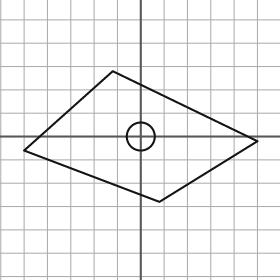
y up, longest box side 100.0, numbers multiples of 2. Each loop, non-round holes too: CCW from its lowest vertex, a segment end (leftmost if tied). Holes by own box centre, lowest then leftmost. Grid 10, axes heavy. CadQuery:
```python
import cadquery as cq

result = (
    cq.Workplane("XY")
    .moveTo(8.0, -28.0)
    .lineTo(50.0, -2.0)
    .lineTo(-12.0, 28.0)
    .lineTo(-50.0, -6.0)
    .close()
    .moveTo(0.0, 0.0)
    .circle(6.0)
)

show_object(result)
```